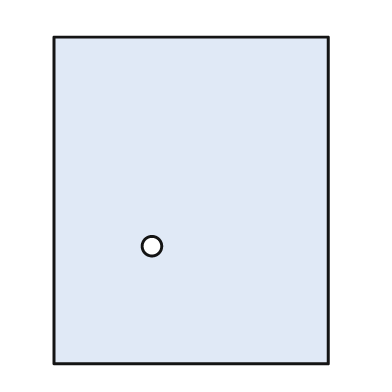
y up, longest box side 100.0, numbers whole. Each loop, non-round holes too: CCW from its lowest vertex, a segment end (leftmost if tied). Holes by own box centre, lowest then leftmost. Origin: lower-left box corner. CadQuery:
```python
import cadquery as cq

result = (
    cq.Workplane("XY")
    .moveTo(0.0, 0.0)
    .lineTo(84.0, 0.0)
    .lineTo(84.0, 100.0)
    .lineTo(0.0, 100.0)
    .close()
    .moveTo(30.0, 36.0)
    .circle(3.0)
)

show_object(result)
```